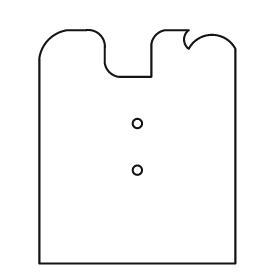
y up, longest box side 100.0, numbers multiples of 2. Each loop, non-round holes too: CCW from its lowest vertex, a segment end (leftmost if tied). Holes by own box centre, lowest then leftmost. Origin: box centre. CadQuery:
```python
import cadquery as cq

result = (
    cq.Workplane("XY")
    .moveTo(-42.0, -50.0)
    .lineTo(42.0, -50.0)
    .lineTo(42.0, 42.0)
    .threePointArc((32.0, 48.0), (22.0, 42.0))
    .threePointArc((20.0, 46.0), (22.0, 50.0))
    .lineTo(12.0, 50.0)
    .threePointArc((8.0, 48.0), (6.0, 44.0))
    .lineTo(6.0, 30.0)
    .lineTo(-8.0, 30.0)
    .threePointArc((-12.0, 32.0), (-14.0, 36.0))
    .lineTo(-14.0, 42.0)
    .threePointArc((-16.0, 48.0), (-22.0, 50.0))
    .lineTo(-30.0, 50.0)
    .threePointArc((-38.0, 46.0), (-42.0, 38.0))
    .close()
    .moveTo(0.0, -10.0)
    .circle(2.0)
    .moveTo(0.0, 10.0)
    .circle(2.0)
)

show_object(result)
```